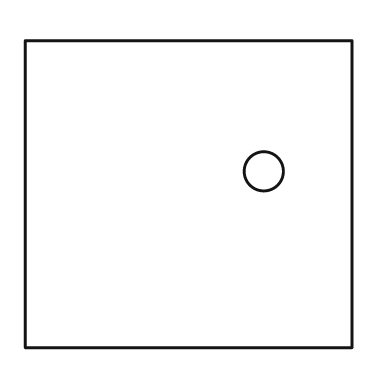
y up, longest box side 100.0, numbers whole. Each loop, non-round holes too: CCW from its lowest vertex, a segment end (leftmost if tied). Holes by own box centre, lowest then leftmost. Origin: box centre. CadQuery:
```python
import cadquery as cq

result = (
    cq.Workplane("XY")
    .moveTo(-50.0, -47.0)
    .lineTo(50.0, -47.0)
    .lineTo(50.0, 47.0)
    .lineTo(-50.0, 47.0)
    .close()
    .moveTo(23.0, 7.0)
    .circle(6.0)
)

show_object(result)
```